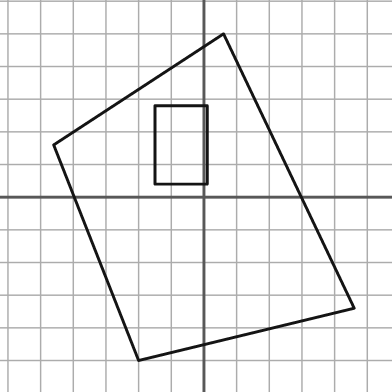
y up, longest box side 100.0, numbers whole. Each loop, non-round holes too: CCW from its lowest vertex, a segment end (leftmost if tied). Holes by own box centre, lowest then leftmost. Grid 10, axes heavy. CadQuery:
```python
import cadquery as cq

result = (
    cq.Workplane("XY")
    .moveTo(-20.0, -50.0)
    .lineTo(46.0, -34.0)
    .lineTo(6.0, 50.0)
    .lineTo(-46.0, 16.0)
    .close()
    .moveTo(-15.0, 4.0)
    .lineTo(1.0, 4.0)
    .lineTo(1.0, 28.0)
    .lineTo(-15.0, 28.0)
    .close()
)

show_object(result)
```